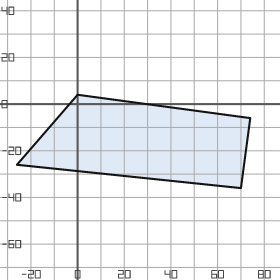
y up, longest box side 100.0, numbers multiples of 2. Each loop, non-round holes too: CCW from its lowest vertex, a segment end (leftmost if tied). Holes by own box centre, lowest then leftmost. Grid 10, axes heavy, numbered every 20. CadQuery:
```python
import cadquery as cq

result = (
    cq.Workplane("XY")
    .moveTo(70.0, -36.0)
    .lineTo(74.0, -6.0)
    .lineTo(0.0, 4.0)
    .lineTo(-26.0, -26.0)
    .close()
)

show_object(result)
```